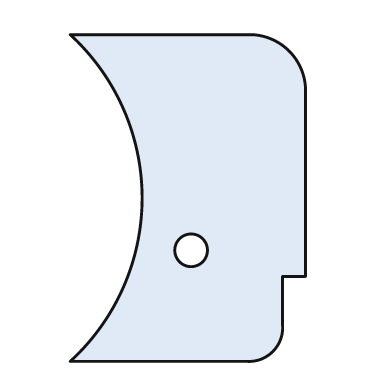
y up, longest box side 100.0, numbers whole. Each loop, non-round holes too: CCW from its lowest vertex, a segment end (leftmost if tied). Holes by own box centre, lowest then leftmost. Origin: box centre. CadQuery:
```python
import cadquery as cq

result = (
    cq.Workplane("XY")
    .moveTo(-36.0, -50.0)
    .lineTo(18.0, -50.0)
    .threePointArc((26.0, -47.0), (29.0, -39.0))
    .lineTo(29.0, -24.0)
    .lineTo(36.0, -24.0)
    .lineTo(36.0, 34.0)
    .threePointArc((31.0, 45.0), (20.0, 50.0))
    .lineTo(-36.0, 50.0)
    .threePointArc((-14.0, 0.0), (-36.0, -50.0))
    .close()
    .moveTo(1.0, -16.0)
    .circle(5.0)
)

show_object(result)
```